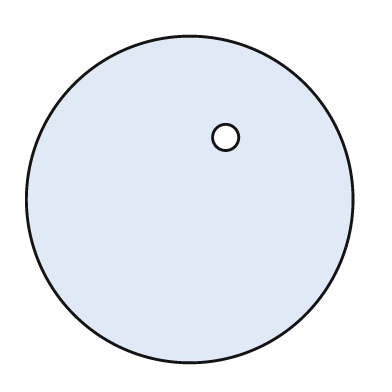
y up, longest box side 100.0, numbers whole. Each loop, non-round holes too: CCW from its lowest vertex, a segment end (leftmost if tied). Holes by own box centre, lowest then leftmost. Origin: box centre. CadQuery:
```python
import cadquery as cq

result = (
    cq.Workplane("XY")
    .moveTo(0.0, 0.0)
    .circle(50.0)
    .moveTo(11.0, 19.0)
    .circle(4.0)
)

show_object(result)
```